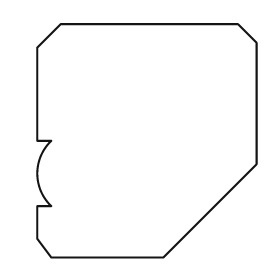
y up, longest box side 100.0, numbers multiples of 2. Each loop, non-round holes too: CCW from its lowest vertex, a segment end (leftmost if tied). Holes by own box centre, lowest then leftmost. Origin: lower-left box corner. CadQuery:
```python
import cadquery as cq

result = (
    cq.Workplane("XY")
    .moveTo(6.0, 0.0)
    .lineTo(54.0, 0.0)
    .lineTo(94.0, 40.0)
    .lineTo(94.0, 92.0)
    .lineTo(86.0, 100.0)
    .lineTo(10.0, 100.0)
    .lineTo(0.0, 90.0)
    .lineTo(0.0, 50.0)
    .lineTo(6.0, 50.0)
    .threePointArc((0.0, 36.0), (6.0, 22.0))
    .lineTo(0.0, 22.0)
    .lineTo(0.0, 8.0)
    .close()
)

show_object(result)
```